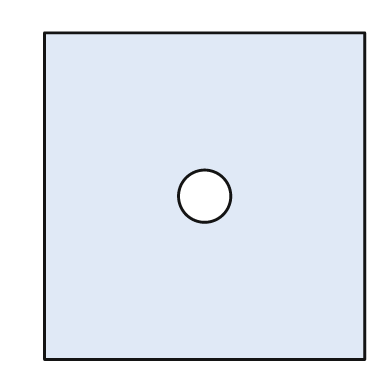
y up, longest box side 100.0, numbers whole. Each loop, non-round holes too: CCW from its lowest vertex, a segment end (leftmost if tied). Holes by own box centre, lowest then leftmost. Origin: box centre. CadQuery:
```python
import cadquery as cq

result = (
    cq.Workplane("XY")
    .moveTo(-49.0, -50.0)
    .lineTo(49.0, -50.0)
    .lineTo(49.0, 50.0)
    .lineTo(-49.0, 50.0)
    .close()
    .moveTo(0.0, 0.0)
    .circle(8.0)
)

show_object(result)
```